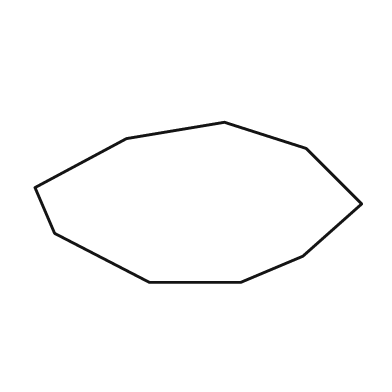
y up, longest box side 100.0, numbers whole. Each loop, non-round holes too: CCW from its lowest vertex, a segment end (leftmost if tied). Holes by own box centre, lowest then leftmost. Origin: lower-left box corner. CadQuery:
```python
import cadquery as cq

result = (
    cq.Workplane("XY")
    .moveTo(35.0, 0.0)
    .lineTo(63.0, 0.0)
    .lineTo(82.0, 8.0)
    .lineTo(100.0, 24.0)
    .lineTo(83.0, 41.0)
    .lineTo(58.0, 49.0)
    .lineTo(28.0, 44.0)
    .lineTo(0.0, 29.0)
    .lineTo(6.0, 15.0)
    .close()
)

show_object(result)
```